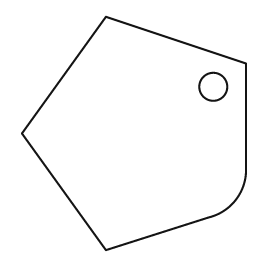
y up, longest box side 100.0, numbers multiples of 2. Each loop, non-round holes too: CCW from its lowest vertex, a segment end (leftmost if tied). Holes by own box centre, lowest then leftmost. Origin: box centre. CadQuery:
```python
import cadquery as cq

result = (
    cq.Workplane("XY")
    .moveTo(-12.0, -50.0)
    .lineTo(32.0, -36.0)
    .threePointArc((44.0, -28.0), (48.0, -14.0))
    .lineTo(48.0, 30.0)
    .lineTo(-12.0, 50.0)
    .lineTo(-48.0, 0.0)
    .close()
    .moveTo(34.0, 20.0)
    .circle(6.0)
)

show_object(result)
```